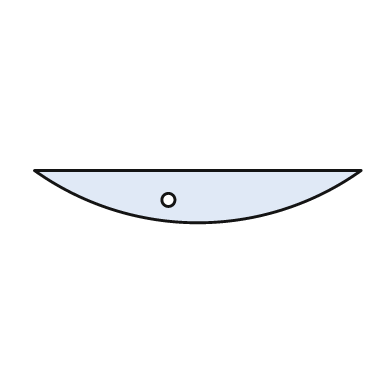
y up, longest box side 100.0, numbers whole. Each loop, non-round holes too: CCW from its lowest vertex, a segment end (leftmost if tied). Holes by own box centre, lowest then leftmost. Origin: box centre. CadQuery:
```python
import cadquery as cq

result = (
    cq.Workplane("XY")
    .moveTo(-50.0, 8.0)
    .threePointArc((0.0, -8.0), (50.0, 8.0))
    .close()
    .moveTo(-9.0, -1.0)
    .circle(2.0)
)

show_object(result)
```